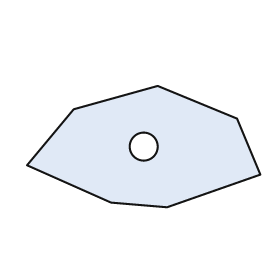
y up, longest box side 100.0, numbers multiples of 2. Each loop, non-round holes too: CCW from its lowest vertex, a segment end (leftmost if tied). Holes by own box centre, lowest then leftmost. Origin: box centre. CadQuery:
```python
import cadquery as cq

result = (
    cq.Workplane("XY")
    .moveTo(10.0, -26.0)
    .lineTo(50.0, -12.0)
    .lineTo(40.0, 12.0)
    .lineTo(6.0, 26.0)
    .lineTo(-30.0, 16.0)
    .lineTo(-50.0, -8.0)
    .lineTo(-14.0, -24.0)
    .close()
    .moveTo(0.0, 0.0)
    .circle(6.0)
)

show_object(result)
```